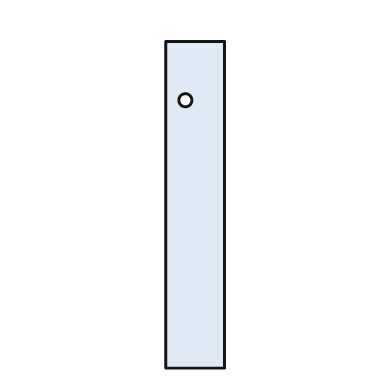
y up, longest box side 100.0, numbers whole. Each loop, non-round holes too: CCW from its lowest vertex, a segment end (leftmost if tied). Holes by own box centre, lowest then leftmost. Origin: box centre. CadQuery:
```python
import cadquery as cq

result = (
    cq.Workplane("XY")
    .moveTo(-9.0, -50.0)
    .lineTo(9.0, -50.0)
    .lineTo(9.0, 50.0)
    .lineTo(-9.0, 50.0)
    .close()
    .moveTo(-3.0, 32.0)
    .circle(2.0)
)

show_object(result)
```